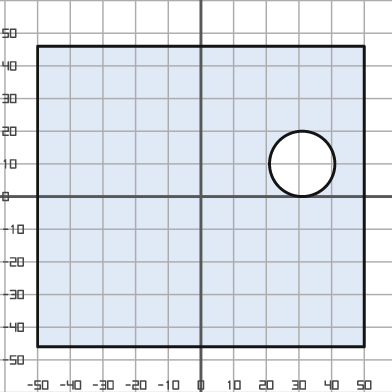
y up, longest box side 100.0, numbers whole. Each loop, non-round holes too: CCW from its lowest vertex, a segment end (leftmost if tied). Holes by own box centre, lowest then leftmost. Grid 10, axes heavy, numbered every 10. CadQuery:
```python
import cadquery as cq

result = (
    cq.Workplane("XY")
    .moveTo(-50.0, -46.0)
    .lineTo(50.0, -46.0)
    .lineTo(50.0, 46.0)
    .lineTo(-50.0, 46.0)
    .close()
    .moveTo(31.0, 10.0)
    .circle(10.0)
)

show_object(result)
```